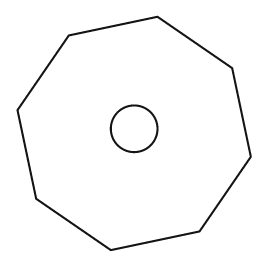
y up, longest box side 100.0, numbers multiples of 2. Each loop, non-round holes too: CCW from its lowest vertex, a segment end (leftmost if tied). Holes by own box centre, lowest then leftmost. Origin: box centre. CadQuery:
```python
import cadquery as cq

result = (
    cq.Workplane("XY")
    .moveTo(-10.0, -50.0)
    .lineTo(28.0, -42.0)
    .lineTo(50.0, -10.0)
    .lineTo(42.0, 28.0)
    .lineTo(10.0, 50.0)
    .lineTo(-28.0, 42.0)
    .lineTo(-50.0, 10.0)
    .lineTo(-42.0, -28.0)
    .close()
    .moveTo(0.0, 2.0)
    .circle(10.0)
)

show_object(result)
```